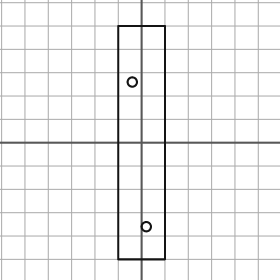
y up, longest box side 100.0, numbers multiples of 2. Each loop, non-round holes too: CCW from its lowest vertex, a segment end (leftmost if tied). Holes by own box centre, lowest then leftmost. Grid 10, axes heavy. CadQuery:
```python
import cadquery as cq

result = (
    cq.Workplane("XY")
    .moveTo(-10.0, -50.0)
    .lineTo(10.0, -50.0)
    .lineTo(10.0, 50.0)
    .lineTo(-10.0, 50.0)
    .close()
    .moveTo(2.0, -36.0)
    .circle(2.0)
    .moveTo(-4.0, 26.0)
    .circle(2.0)
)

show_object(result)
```